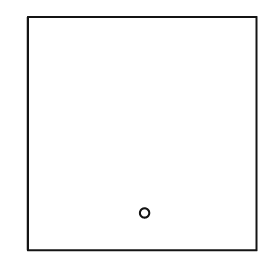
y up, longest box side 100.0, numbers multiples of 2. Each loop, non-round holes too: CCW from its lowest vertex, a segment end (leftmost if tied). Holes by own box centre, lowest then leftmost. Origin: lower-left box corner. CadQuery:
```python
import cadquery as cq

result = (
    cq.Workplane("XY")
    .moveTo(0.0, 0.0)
    .lineTo(98.0, 0.0)
    .lineTo(98.0, 100.0)
    .lineTo(0.0, 100.0)
    .close()
    .moveTo(50.0, 16.0)
    .circle(2.0)
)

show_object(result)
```